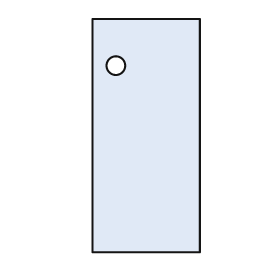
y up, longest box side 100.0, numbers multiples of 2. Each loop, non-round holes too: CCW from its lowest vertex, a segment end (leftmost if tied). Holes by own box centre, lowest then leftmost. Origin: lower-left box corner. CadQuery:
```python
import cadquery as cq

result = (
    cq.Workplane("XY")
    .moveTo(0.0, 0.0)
    .lineTo(46.0, 0.0)
    .lineTo(46.0, 100.0)
    .lineTo(0.0, 100.0)
    .close()
    .moveTo(10.0, 80.0)
    .circle(4.0)
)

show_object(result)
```